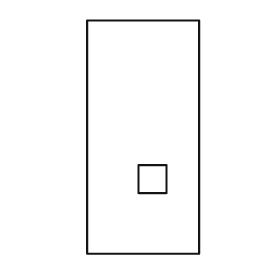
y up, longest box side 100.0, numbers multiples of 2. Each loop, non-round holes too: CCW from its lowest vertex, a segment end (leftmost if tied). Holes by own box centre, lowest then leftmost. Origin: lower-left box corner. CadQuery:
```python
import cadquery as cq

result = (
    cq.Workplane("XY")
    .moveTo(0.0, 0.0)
    .lineTo(48.0, 0.0)
    .lineTo(48.0, 100.0)
    .lineTo(0.0, 100.0)
    .close()
    .moveTo(22.0, 26.0)
    .lineTo(34.0, 26.0)
    .lineTo(34.0, 38.0)
    .lineTo(22.0, 38.0)
    .close()
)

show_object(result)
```